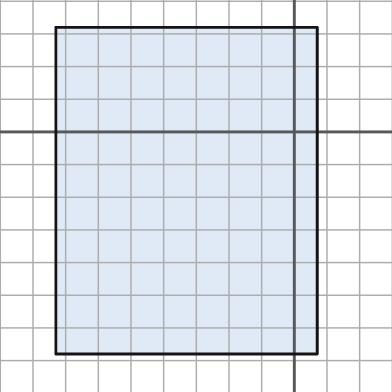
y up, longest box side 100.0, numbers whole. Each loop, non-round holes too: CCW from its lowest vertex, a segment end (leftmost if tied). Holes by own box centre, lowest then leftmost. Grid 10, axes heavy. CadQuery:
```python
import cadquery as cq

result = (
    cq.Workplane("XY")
    .moveTo(-73.0, -68.0)
    .lineTo(7.0, -68.0)
    .lineTo(7.0, 32.0)
    .lineTo(-73.0, 32.0)
    .close()
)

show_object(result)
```